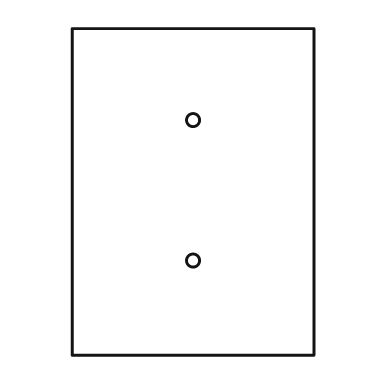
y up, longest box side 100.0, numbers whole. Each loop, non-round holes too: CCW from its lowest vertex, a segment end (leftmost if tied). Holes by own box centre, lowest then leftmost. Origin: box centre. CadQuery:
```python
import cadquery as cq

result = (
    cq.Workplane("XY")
    .moveTo(-37.0, -50.0)
    .lineTo(37.0, -50.0)
    .lineTo(37.0, 50.0)
    .lineTo(-37.0, 50.0)
    .close()
    .moveTo(0.0, -21.0)
    .circle(2.0)
    .moveTo(0.0, 22.0)
    .circle(2.0)
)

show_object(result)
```